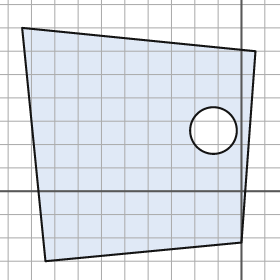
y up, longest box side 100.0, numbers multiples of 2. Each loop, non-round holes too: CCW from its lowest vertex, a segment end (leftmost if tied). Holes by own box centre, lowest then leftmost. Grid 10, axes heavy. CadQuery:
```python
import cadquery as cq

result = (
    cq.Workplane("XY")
    .moveTo(-84.0, -30.0)
    .lineTo(0.0, -22.0)
    .lineTo(6.0, 60.0)
    .lineTo(-94.0, 70.0)
    .close()
    .moveTo(-12.0, 26.0)
    .circle(10.0)
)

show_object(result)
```